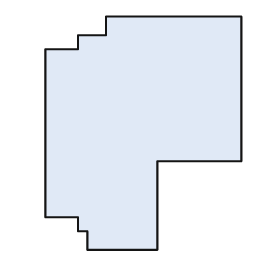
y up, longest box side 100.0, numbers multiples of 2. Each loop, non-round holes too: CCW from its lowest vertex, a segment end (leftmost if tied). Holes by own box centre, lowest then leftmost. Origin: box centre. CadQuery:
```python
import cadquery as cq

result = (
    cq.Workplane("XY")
    .moveTo(-24.0, -50.0)
    .lineTo(6.0, -50.0)
    .lineTo(6.0, -12.0)
    .lineTo(42.0, -12.0)
    .lineTo(42.0, 50.0)
    .lineTo(-16.0, 50.0)
    .lineTo(-16.0, 42.0)
    .lineTo(-28.0, 42.0)
    .lineTo(-28.0, 36.0)
    .lineTo(-42.0, 36.0)
    .lineTo(-42.0, -36.0)
    .lineTo(-28.0, -36.0)
    .lineTo(-28.0, -42.0)
    .lineTo(-24.0, -42.0)
    .close()
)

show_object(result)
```